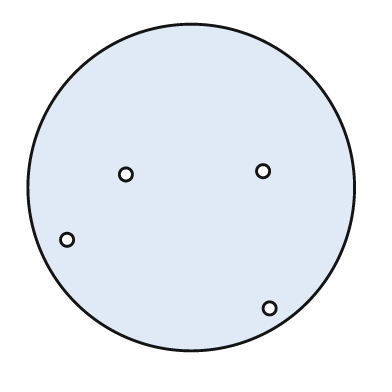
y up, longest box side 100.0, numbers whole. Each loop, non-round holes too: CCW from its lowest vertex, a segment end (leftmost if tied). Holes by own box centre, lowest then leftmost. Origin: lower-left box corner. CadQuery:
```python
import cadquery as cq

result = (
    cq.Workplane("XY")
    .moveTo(50.0, 50.0)
    .circle(50.0)
    .moveTo(74.0, 13.0)
    .circle(2.0)
    .moveTo(12.0, 34.0)
    .circle(2.0)
    .moveTo(30.0, 54.0)
    .circle(2.0)
    .moveTo(72.0, 55.0)
    .circle(2.0)
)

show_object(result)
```